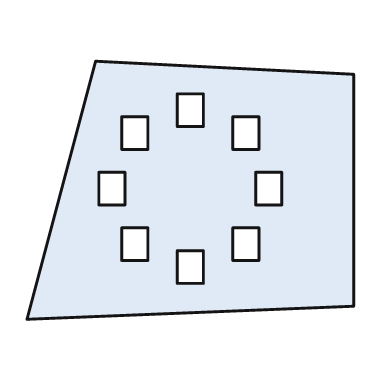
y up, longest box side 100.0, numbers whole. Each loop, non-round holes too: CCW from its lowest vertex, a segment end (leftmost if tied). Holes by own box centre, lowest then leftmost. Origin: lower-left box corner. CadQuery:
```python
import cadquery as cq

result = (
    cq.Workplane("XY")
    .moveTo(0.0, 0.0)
    .lineTo(100.0, 4.0)
    .lineTo(100.0, 75.0)
    .lineTo(21.0, 79.0)
    .close()
    .moveTo(46.0, 11.0)
    .lineTo(54.0, 11.0)
    .lineTo(54.0, 21.0)
    .lineTo(46.0, 21.0)
    .close()
    .moveTo(29.0, 18.0)
    .lineTo(37.0, 18.0)
    .lineTo(37.0, 28.0)
    .lineTo(29.0, 28.0)
    .close()
    .moveTo(63.0, 18.0)
    .lineTo(71.0, 18.0)
    .lineTo(71.0, 28.0)
    .lineTo(63.0, 28.0)
    .close()
    .moveTo(22.0, 35.0)
    .lineTo(30.0, 35.0)
    .lineTo(30.0, 45.0)
    .lineTo(22.0, 45.0)
    .close()
    .moveTo(70.0, 35.0)
    .lineTo(78.0, 35.0)
    .lineTo(78.0, 45.0)
    .lineTo(70.0, 45.0)
    .close()
    .moveTo(29.0, 52.0)
    .lineTo(37.0, 52.0)
    .lineTo(37.0, 62.0)
    .lineTo(29.0, 62.0)
    .close()
    .moveTo(63.0, 52.0)
    .lineTo(71.0, 52.0)
    .lineTo(71.0, 62.0)
    .lineTo(63.0, 62.0)
    .close()
    .moveTo(46.0, 59.0)
    .lineTo(54.0, 59.0)
    .lineTo(54.0, 69.0)
    .lineTo(46.0, 69.0)
    .close()
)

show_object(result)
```